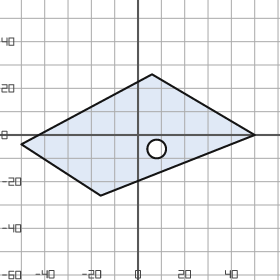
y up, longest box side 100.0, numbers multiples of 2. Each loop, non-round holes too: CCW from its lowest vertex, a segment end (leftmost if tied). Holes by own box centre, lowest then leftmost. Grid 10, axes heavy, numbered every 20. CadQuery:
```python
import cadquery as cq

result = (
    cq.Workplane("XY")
    .moveTo(-16.0, -26.0)
    .lineTo(50.0, 0.0)
    .lineTo(6.0, 26.0)
    .lineTo(-50.0, -4.0)
    .close()
    .moveTo(8.0, -6.0)
    .circle(4.0)
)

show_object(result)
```